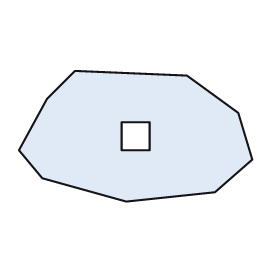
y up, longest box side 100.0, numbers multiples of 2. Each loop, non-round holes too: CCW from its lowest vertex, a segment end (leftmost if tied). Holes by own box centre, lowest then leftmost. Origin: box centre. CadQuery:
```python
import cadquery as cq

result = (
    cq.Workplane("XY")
    .moveTo(-4.0, -28.0)
    .lineTo(34.0, -24.0)
    .lineTo(50.0, -10.0)
    .lineTo(44.0, 10.0)
    .lineTo(22.0, 26.0)
    .lineTo(-26.0, 28.0)
    .lineTo(-38.0, 16.0)
    .lineTo(-50.0, -6.0)
    .lineTo(-40.0, -18.0)
    .close()
    .moveTo(-6.0, -6.0)
    .lineTo(6.0, -6.0)
    .lineTo(6.0, 6.0)
    .lineTo(-6.0, 6.0)
    .close()
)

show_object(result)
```